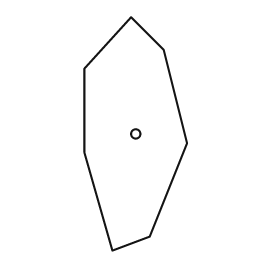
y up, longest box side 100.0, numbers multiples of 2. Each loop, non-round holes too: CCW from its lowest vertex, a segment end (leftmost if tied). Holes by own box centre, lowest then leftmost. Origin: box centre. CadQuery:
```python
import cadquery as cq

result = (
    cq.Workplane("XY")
    .moveTo(-10.0, -50.0)
    .lineTo(6.0, -44.0)
    .lineTo(22.0, -4.0)
    .lineTo(12.0, 36.0)
    .lineTo(-2.0, 50.0)
    .lineTo(-22.0, 28.0)
    .lineTo(-22.0, -8.0)
    .close()
    .moveTo(0.0, 0.0)
    .circle(2.0)
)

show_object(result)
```